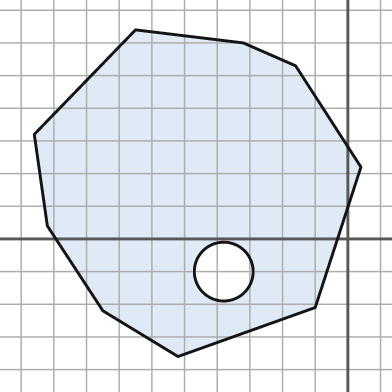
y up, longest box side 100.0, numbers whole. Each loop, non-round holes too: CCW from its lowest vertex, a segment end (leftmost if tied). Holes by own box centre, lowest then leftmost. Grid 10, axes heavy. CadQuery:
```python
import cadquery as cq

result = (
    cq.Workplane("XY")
    .moveTo(-52.0, -36.0)
    .lineTo(-10.0, -21.0)
    .lineTo(4.0, 22.0)
    .lineTo(-16.0, 53.0)
    .lineTo(-32.0, 60.0)
    .lineTo(-65.0, 64.0)
    .lineTo(-96.0, 32.0)
    .lineTo(-92.0, 4.0)
    .lineTo(-75.0, -22.0)
    .close()
    .moveTo(-38.0, -10.0)
    .circle(9.0)
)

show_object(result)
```